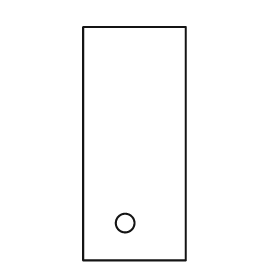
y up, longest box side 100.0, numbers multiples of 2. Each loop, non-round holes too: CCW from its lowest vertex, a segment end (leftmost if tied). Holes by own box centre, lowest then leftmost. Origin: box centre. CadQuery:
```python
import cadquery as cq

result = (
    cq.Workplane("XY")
    .moveTo(-22.0, -50.0)
    .lineTo(22.0, -50.0)
    .lineTo(22.0, 50.0)
    .lineTo(-22.0, 50.0)
    .close()
    .moveTo(-4.0, -34.0)
    .circle(4.0)
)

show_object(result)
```